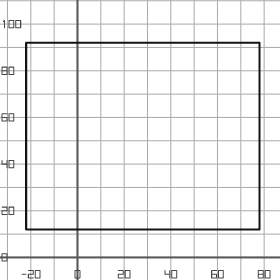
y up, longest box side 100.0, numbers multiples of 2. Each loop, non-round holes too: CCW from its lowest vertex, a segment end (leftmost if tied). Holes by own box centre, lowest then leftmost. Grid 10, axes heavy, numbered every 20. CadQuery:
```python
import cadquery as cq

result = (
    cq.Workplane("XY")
    .moveTo(-22.0, 12.0)
    .lineTo(78.0, 12.0)
    .lineTo(78.0, 92.0)
    .lineTo(-22.0, 92.0)
    .close()
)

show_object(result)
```